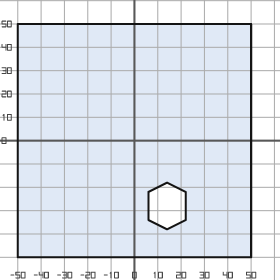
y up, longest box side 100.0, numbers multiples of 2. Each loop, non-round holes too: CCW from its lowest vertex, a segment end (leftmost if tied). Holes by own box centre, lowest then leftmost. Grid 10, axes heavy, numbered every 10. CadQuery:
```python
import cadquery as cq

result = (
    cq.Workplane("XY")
    .moveTo(-50.0, -50.0)
    .lineTo(50.0, -50.0)
    .lineTo(50.0, 50.0)
    .lineTo(-50.0, 50.0)
    .close()
    .moveTo(14.0, -38.0)
    .lineTo(22.0, -34.0)
    .lineTo(22.0, -22.0)
    .lineTo(14.0, -18.0)
    .lineTo(6.0, -22.0)
    .lineTo(6.0, -34.0)
    .close()
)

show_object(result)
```